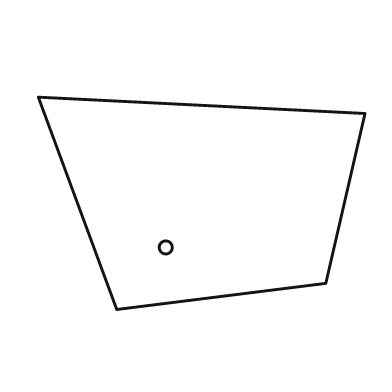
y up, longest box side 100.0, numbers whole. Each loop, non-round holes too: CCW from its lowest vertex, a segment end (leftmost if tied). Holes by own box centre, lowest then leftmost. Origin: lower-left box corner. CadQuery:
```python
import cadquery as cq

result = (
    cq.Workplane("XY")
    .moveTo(24.0, 0.0)
    .lineTo(88.0, 8.0)
    .lineTo(100.0, 60.0)
    .lineTo(0.0, 65.0)
    .close()
    .moveTo(39.0, 19.0)
    .circle(2.0)
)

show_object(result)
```